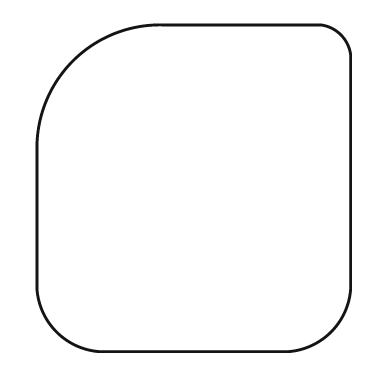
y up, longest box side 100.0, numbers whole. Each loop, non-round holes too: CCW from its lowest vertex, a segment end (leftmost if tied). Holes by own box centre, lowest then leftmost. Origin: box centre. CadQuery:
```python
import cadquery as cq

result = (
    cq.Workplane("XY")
    .moveTo(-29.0, -50.0)
    .lineTo(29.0, -50.0)
    .threePointArc((42.0, -44.0), (48.0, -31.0))
    .lineTo(48.0, 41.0)
    .threePointArc((45.0, 47.0), (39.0, 50.0))
    .lineTo(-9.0, 50.0)
    .threePointArc((-37.0, 39.0), (-48.0, 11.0))
    .lineTo(-48.0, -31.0)
    .threePointArc((-42.0, -44.0), (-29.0, -50.0))
    .close()
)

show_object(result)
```